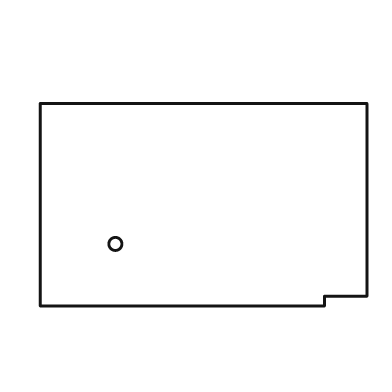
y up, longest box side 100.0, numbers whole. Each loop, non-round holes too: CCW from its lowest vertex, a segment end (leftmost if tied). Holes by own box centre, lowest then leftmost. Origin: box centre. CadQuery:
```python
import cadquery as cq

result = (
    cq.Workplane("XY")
    .moveTo(-50.0, -31.0)
    .lineTo(37.0, -31.0)
    .lineTo(37.0, -28.0)
    .lineTo(50.0, -28.0)
    .lineTo(50.0, 31.0)
    .lineTo(-50.0, 31.0)
    .close()
    .moveTo(-27.0, -12.0)
    .circle(2.0)
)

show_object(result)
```